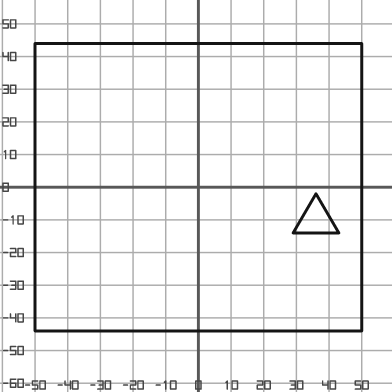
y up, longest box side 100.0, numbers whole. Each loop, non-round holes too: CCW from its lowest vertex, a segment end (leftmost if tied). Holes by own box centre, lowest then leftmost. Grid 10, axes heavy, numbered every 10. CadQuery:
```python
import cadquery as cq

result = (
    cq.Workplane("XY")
    .moveTo(-50.0, -44.0)
    .lineTo(50.0, -44.0)
    .lineTo(50.0, 44.0)
    .lineTo(-50.0, 44.0)
    .close()
    .moveTo(29.0, -14.0)
    .lineTo(43.0, -14.0)
    .lineTo(36.0, -2.0)
    .close()
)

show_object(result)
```